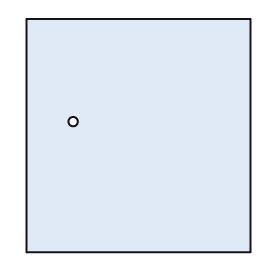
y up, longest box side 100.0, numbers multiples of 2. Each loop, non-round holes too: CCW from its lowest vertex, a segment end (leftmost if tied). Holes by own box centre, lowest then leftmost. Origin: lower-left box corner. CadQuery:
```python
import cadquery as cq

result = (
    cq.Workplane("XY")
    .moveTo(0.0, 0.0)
    .lineTo(96.0, 0.0)
    .lineTo(96.0, 100.0)
    .lineTo(0.0, 100.0)
    .close()
    .moveTo(20.0, 56.0)
    .circle(2.0)
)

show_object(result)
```